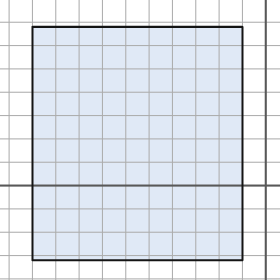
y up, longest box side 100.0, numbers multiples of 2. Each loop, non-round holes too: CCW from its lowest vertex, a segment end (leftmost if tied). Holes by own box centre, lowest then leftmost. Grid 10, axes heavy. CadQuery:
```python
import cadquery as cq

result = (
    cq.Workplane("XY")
    .moveTo(-100.0, -32.0)
    .lineTo(-10.0, -32.0)
    .lineTo(-10.0, 68.0)
    .lineTo(-100.0, 68.0)
    .close()
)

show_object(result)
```